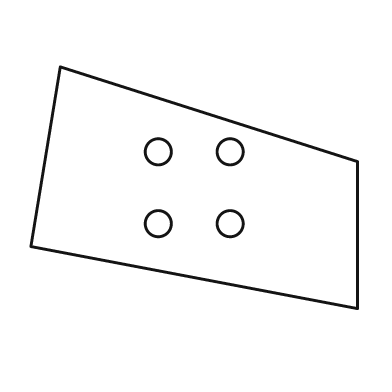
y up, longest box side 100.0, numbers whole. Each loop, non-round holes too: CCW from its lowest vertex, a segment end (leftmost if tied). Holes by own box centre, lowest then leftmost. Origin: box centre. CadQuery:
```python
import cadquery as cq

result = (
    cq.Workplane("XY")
    .moveTo(50.0, -37.0)
    .lineTo(50.0, 8.0)
    .lineTo(-41.0, 37.0)
    .lineTo(-50.0, -18.0)
    .close()
    .moveTo(-11.0, -11.0)
    .circle(4.0)
    .moveTo(11.0, -11.0)
    .circle(4.0)
    .moveTo(-11.0, 11.0)
    .circle(4.0)
    .moveTo(11.0, 11.0)
    .circle(4.0)
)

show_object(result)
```